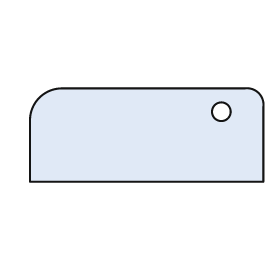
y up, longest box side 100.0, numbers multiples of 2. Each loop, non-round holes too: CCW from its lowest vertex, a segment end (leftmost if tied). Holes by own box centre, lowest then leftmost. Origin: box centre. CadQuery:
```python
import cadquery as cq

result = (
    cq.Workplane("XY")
    .moveTo(-50.0, -20.0)
    .lineTo(50.0, -20.0)
    .lineTo(50.0, 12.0)
    .threePointArc((48.0, 18.0), (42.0, 20.0))
    .lineTo(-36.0, 20.0)
    .threePointArc((-46.0, 16.0), (-50.0, 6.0))
    .close()
    .moveTo(32.0, 10.0)
    .circle(4.0)
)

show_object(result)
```